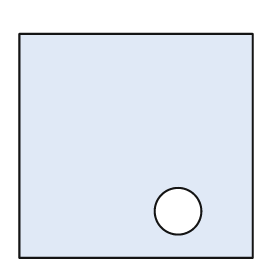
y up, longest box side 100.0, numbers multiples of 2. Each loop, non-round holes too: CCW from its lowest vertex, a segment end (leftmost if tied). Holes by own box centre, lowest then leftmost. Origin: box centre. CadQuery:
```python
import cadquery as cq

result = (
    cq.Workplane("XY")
    .moveTo(-50.0, -48.0)
    .lineTo(50.0, -48.0)
    .lineTo(50.0, 48.0)
    .lineTo(-50.0, 48.0)
    .close()
    .moveTo(18.0, -28.0)
    .circle(10.0)
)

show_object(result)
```